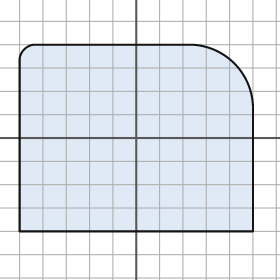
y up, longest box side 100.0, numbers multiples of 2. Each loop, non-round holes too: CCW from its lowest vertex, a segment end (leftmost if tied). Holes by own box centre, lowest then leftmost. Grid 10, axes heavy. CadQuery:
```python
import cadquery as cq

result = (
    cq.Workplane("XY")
    .moveTo(-50.0, -40.0)
    .lineTo(50.0, -40.0)
    .lineTo(50.0, 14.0)
    .threePointArc((42.0, 32.0), (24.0, 40.0))
    .lineTo(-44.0, 40.0)
    .threePointArc((-48.0, 38.0), (-50.0, 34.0))
    .close()
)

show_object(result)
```